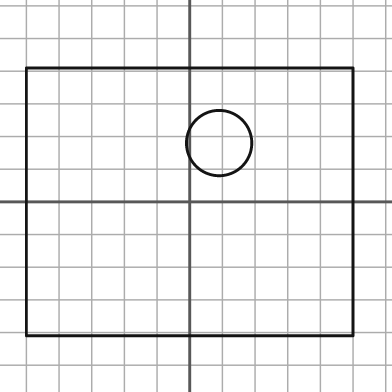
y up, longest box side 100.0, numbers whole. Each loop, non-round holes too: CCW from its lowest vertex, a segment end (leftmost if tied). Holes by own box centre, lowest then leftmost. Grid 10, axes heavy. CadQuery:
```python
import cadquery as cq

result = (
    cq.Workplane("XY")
    .moveTo(-50.0, -41.0)
    .lineTo(50.0, -41.0)
    .lineTo(50.0, 41.0)
    .lineTo(-50.0, 41.0)
    .close()
    .moveTo(9.0, 18.0)
    .circle(10.0)
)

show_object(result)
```